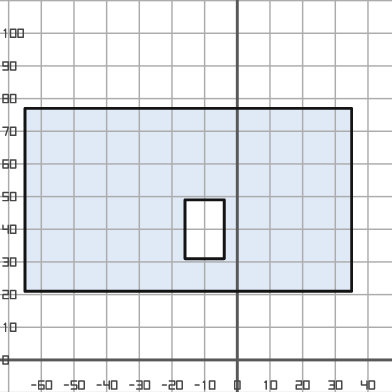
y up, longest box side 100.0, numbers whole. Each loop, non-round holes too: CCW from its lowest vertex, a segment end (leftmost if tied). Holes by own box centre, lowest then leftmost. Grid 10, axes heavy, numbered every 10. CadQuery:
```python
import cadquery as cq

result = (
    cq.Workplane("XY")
    .moveTo(-65.0, 21.0)
    .lineTo(35.0, 21.0)
    .lineTo(35.0, 77.0)
    .lineTo(-65.0, 77.0)
    .close()
    .moveTo(-16.0, 31.0)
    .lineTo(-4.0, 31.0)
    .lineTo(-4.0, 49.0)
    .lineTo(-16.0, 49.0)
    .close()
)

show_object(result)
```